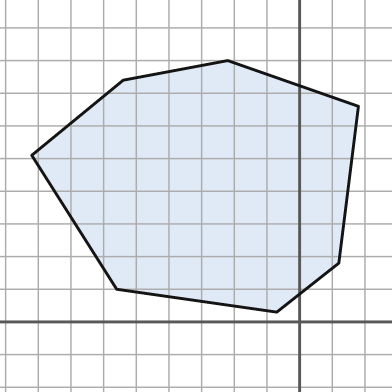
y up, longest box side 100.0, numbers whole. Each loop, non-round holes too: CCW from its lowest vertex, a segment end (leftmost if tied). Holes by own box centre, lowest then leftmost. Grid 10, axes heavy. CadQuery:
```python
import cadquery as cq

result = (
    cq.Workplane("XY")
    .moveTo(-7.0, 3.0)
    .lineTo(12.0, 18.0)
    .lineTo(18.0, 66.0)
    .lineTo(-22.0, 80.0)
    .lineTo(-54.0, 74.0)
    .lineTo(-82.0, 51.0)
    .lineTo(-56.0, 10.0)
    .close()
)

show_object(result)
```